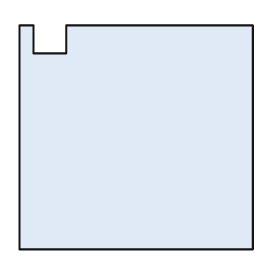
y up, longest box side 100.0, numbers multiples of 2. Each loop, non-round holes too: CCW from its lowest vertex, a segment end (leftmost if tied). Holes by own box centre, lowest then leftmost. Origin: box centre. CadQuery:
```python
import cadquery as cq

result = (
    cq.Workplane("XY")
    .moveTo(-50.0, -48.0)
    .lineTo(50.0, -48.0)
    .lineTo(50.0, 48.0)
    .lineTo(-30.0, 48.0)
    .lineTo(-30.0, 36.0)
    .lineTo(-44.0, 36.0)
    .lineTo(-44.0, 48.0)
    .lineTo(-50.0, 48.0)
    .close()
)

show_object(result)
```